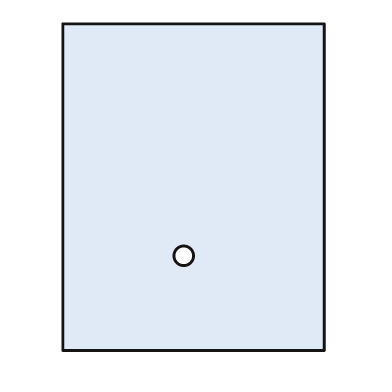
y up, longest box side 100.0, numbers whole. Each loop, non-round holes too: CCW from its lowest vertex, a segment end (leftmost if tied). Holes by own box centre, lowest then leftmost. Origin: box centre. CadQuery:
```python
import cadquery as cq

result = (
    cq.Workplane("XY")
    .moveTo(-40.0, -50.0)
    .lineTo(40.0, -50.0)
    .lineTo(40.0, 50.0)
    .lineTo(-40.0, 50.0)
    .close()
    .moveTo(-3.0, -21.0)
    .circle(3.0)
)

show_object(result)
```